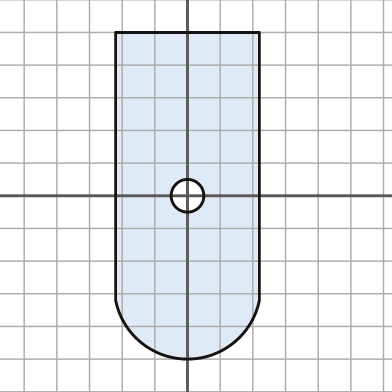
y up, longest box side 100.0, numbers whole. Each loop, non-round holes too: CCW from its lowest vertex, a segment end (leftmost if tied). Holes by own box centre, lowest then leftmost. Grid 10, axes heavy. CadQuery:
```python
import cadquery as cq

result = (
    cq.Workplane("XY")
    .moveTo(-22.0, -32.0)
    .threePointArc((0.0, -50.0), (22.0, -32.0))
    .lineTo(22.0, 50.0)
    .lineTo(-22.0, 50.0)
    .close()
    .moveTo(0.0, 0.0)
    .circle(5.0)
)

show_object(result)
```